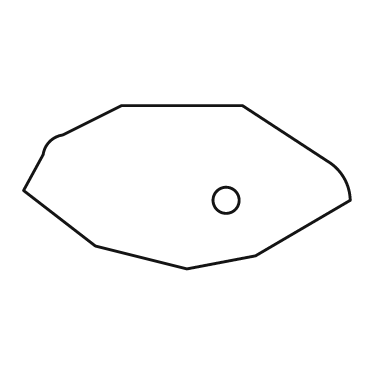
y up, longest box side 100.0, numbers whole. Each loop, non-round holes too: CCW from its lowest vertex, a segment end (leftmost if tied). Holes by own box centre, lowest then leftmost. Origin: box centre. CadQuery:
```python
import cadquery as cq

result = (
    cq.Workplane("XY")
    .moveTo(0.0, -25.0)
    .lineTo(21.0, -21.0)
    .lineTo(50.0, -4.0)
    .threePointArc((48.0, 3.0), (43.0, 8.0))
    .lineTo(17.0, 25.0)
    .lineTo(-20.0, 25.0)
    .lineTo(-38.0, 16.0)
    .threePointArc((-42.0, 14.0), (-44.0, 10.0))
    .lineTo(-50.0, -1.0)
    .lineTo(-28.0, -18.0)
    .close()
    .moveTo(12.0, -4.0)
    .circle(4.0)
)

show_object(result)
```